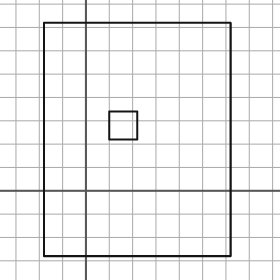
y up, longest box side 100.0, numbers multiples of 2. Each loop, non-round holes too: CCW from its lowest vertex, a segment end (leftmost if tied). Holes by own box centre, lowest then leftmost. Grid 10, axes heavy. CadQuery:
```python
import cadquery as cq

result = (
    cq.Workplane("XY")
    .moveTo(-18.0, -28.0)
    .lineTo(62.0, -28.0)
    .lineTo(62.0, 72.0)
    .lineTo(-18.0, 72.0)
    .close()
    .moveTo(10.0, 22.0)
    .lineTo(22.0, 22.0)
    .lineTo(22.0, 34.0)
    .lineTo(10.0, 34.0)
    .close()
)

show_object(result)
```